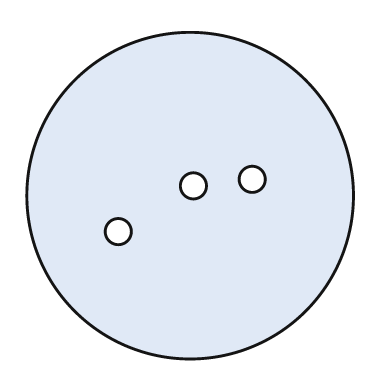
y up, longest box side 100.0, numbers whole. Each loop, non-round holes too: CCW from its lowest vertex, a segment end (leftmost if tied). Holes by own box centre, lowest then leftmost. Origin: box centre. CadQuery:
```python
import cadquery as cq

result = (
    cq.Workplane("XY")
    .moveTo(0.0, 0.0)
    .circle(50.0)
    .moveTo(-22.0, -11.0)
    .circle(4.0)
    .moveTo(1.0, 3.0)
    .circle(4.0)
    .moveTo(19.0, 5.0)
    .circle(4.0)
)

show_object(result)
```